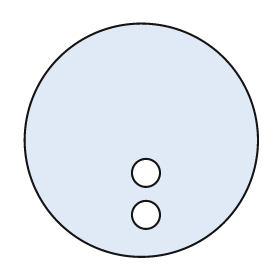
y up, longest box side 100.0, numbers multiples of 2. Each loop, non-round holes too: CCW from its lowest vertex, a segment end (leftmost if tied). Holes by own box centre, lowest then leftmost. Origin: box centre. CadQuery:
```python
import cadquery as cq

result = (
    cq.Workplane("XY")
    .moveTo(0.0, 0.0)
    .circle(50.0)
    .moveTo(2.0, -32.0)
    .circle(6.0)
    .moveTo(2.0, -14.0)
    .circle(6.0)
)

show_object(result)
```